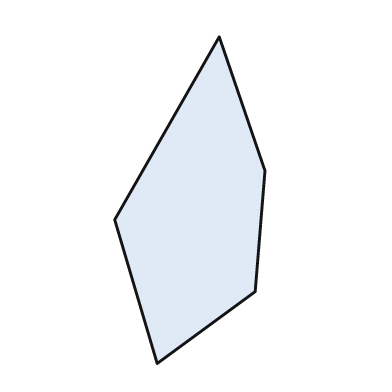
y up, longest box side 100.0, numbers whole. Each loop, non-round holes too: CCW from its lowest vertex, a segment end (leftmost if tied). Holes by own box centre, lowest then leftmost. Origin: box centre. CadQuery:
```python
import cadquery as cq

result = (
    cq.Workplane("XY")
    .moveTo(-10.0, -50.0)
    .lineTo(20.0, -28.0)
    .lineTo(23.0, 9.0)
    .lineTo(9.0, 50.0)
    .lineTo(-23.0, -6.0)
    .close()
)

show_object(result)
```